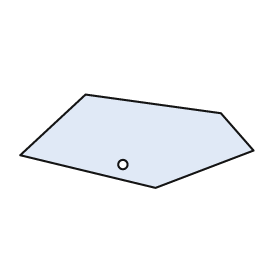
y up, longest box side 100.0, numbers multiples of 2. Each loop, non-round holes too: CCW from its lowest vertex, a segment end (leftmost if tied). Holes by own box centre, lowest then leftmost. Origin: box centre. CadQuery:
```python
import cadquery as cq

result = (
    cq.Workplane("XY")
    .moveTo(8.0, -20.0)
    .lineTo(50.0, -4.0)
    .lineTo(36.0, 12.0)
    .lineTo(-22.0, 20.0)
    .lineTo(-50.0, -6.0)
    .close()
    .moveTo(-6.0, -10.0)
    .circle(2.0)
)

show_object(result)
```